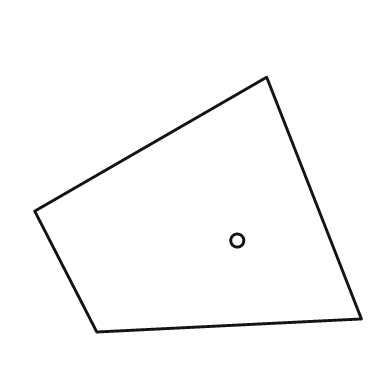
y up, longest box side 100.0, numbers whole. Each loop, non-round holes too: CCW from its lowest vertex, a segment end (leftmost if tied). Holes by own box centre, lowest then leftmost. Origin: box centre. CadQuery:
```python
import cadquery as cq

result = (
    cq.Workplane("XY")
    .moveTo(-31.0, -39.0)
    .lineTo(50.0, -35.0)
    .lineTo(21.0, 39.0)
    .lineTo(-50.0, -2.0)
    .close()
    .moveTo(12.0, -11.0)
    .circle(2.0)
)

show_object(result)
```